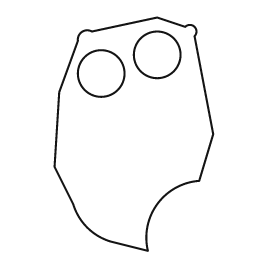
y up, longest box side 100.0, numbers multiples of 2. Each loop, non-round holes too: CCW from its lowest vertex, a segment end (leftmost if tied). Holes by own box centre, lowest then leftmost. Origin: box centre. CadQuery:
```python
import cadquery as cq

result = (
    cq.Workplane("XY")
    .moveTo(6.0, -50.0)
    .threePointArc((10.0, -30.0), (28.0, -20.0))
    .lineTo(34.0, 0.0)
    .lineTo(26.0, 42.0)
    .threePointArc((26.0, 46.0), (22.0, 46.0))
    .lineTo(10.0, 50.0)
    .lineTo(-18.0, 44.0)
    .threePointArc((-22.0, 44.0), (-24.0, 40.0))
    .lineTo(-32.0, 18.0)
    .lineTo(-34.0, -14.0)
    .lineTo(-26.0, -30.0)
    .threePointArc((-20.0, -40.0), (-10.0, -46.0))
    .close()
    .moveTo(-14.0, 26.0)
    .circle(10.0)
    .moveTo(10.0, 34.0)
    .circle(10.0)
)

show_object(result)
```